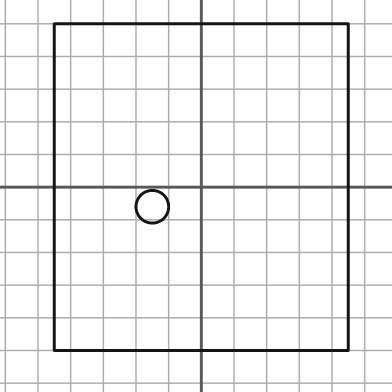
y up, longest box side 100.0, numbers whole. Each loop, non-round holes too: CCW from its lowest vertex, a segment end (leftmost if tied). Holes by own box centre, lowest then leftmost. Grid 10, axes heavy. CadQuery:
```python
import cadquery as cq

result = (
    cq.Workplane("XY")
    .moveTo(-45.0, -50.0)
    .lineTo(45.0, -50.0)
    .lineTo(45.0, 50.0)
    .lineTo(-45.0, 50.0)
    .close()
    .moveTo(-15.0, -6.0)
    .circle(5.0)
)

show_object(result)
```